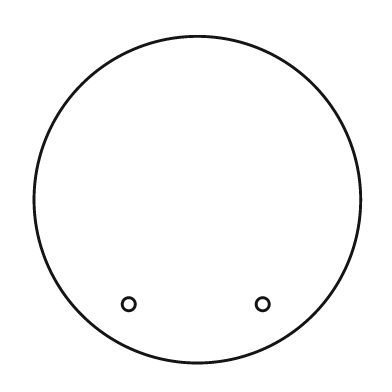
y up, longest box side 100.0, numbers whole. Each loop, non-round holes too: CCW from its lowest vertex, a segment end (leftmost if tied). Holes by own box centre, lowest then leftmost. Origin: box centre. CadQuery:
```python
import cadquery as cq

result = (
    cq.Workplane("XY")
    .moveTo(0.0, 0.0)
    .circle(50.0)
    .moveTo(-21.0, -32.0)
    .circle(2.0)
    .moveTo(20.0, -32.0)
    .circle(2.0)
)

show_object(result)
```